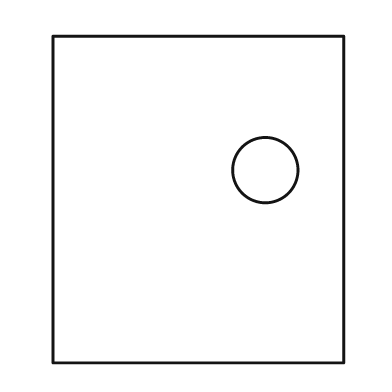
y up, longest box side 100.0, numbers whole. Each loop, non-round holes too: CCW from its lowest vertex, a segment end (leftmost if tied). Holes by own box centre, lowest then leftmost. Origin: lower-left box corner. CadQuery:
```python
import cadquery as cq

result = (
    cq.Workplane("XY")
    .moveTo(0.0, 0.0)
    .lineTo(89.0, 0.0)
    .lineTo(89.0, 100.0)
    .lineTo(0.0, 100.0)
    .close()
    .moveTo(65.0, 59.0)
    .circle(10.0)
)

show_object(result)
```